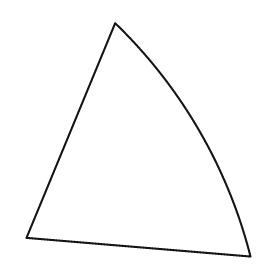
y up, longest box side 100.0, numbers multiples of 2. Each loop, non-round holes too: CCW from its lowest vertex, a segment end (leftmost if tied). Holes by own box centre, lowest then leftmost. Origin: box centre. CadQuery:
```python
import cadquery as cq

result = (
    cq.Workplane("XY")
    .moveTo(48.0, -50.0)
    .threePointArc((26.0, 4.0), (-10.0, 50.0))
    .lineTo(-48.0, -42.0)
    .close()
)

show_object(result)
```